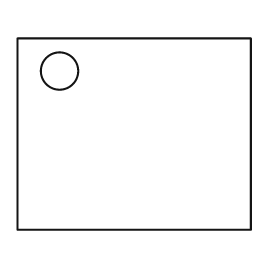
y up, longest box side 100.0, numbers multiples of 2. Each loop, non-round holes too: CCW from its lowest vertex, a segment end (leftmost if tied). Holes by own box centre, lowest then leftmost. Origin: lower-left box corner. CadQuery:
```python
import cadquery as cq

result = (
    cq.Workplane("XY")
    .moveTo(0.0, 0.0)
    .lineTo(100.0, 0.0)
    .lineTo(100.0, 82.0)
    .lineTo(0.0, 82.0)
    .close()
    .moveTo(18.0, 68.0)
    .circle(8.0)
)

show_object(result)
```